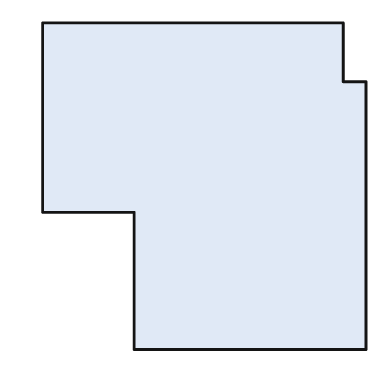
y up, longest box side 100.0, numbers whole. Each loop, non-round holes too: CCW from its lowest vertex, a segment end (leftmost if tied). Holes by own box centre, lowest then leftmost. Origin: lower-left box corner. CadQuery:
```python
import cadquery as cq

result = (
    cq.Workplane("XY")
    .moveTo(28.0, 0.0)
    .lineTo(99.0, 0.0)
    .lineTo(99.0, 82.0)
    .lineTo(92.0, 82.0)
    .lineTo(92.0, 100.0)
    .lineTo(0.0, 100.0)
    .lineTo(0.0, 42.0)
    .lineTo(28.0, 42.0)
    .close()
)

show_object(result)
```